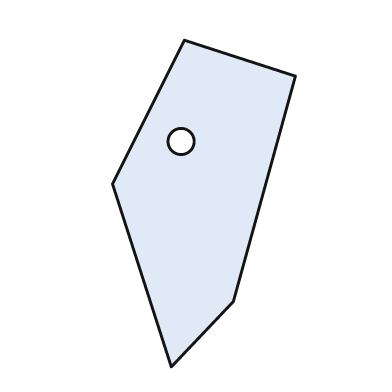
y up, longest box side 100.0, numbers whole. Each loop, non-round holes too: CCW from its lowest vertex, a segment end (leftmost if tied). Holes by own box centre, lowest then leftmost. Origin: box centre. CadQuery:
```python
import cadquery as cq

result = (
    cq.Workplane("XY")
    .moveTo(-10.0, -50.0)
    .lineTo(9.0, -30.0)
    .lineTo(28.0, 39.0)
    .lineTo(-6.0, 50.0)
    .lineTo(-28.0, 6.0)
    .close()
    .moveTo(-7.0, 19.0)
    .circle(4.0)
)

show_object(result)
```